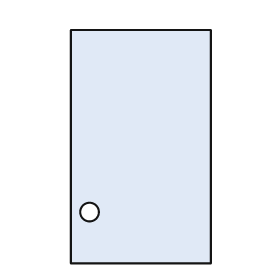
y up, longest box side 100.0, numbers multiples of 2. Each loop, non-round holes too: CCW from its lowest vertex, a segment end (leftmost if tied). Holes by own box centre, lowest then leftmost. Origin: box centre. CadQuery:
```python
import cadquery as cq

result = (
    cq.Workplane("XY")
    .moveTo(-30.0, -50.0)
    .lineTo(30.0, -50.0)
    .lineTo(30.0, 50.0)
    .lineTo(-30.0, 50.0)
    .close()
    .moveTo(-22.0, -28.0)
    .circle(4.0)
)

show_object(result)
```